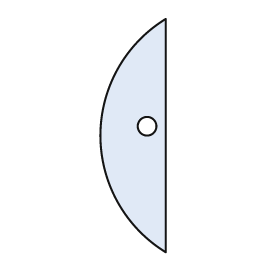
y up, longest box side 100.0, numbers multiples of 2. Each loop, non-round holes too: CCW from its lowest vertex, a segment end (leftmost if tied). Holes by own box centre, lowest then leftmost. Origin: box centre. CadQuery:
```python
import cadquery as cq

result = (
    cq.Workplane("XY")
    .moveTo(14.0, -50.0)
    .lineTo(14.0, 50.0)
    .threePointArc((-14.0, 0.0), (14.0, -50.0))
    .close()
    .moveTo(6.0, 4.0)
    .circle(4.0)
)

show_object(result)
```